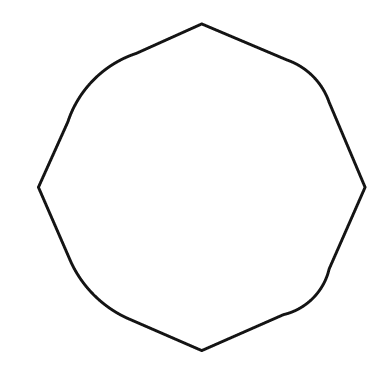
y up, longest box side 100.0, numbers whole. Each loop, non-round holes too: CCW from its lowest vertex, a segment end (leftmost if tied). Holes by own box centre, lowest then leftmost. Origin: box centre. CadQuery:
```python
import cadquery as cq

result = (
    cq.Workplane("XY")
    .moveTo(0.0, -50.0)
    .lineTo(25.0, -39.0)
    .threePointArc((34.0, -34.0), (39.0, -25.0))
    .lineTo(50.0, 0.0)
    .lineTo(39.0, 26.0)
    .threePointArc((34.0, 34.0), (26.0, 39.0))
    .lineTo(0.0, 50.0)
    .lineTo(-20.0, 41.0)
    .threePointArc((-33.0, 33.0), (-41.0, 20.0))
    .lineTo(-50.0, 0.0)
    .lineTo(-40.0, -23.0)
    .threePointArc((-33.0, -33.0), (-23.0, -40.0))
    .close()
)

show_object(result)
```